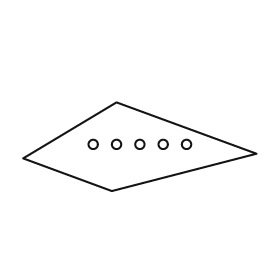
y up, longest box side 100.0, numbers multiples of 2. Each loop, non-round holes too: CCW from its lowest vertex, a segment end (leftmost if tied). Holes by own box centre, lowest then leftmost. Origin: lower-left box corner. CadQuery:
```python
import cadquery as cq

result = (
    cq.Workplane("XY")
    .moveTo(38.0, 0.0)
    .lineTo(100.0, 16.0)
    .lineTo(40.0, 38.0)
    .lineTo(0.0, 14.0)
    .close()
    .moveTo(30.0, 20.0)
    .circle(2.0)
    .moveTo(40.0, 20.0)
    .circle(2.0)
    .moveTo(50.0, 20.0)
    .circle(2.0)
    .moveTo(60.0, 20.0)
    .circle(2.0)
    .moveTo(70.0, 20.0)
    .circle(2.0)
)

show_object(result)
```